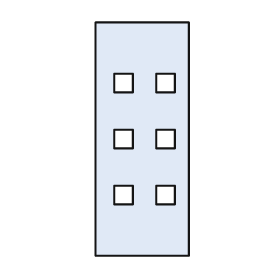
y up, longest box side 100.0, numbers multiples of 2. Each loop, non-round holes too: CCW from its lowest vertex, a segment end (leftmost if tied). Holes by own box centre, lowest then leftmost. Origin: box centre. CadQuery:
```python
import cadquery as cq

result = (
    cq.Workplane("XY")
    .moveTo(-20.0, -50.0)
    .lineTo(20.0, -50.0)
    .lineTo(20.0, 50.0)
    .lineTo(-20.0, 50.0)
    .close()
    .moveTo(-12.0, -28.0)
    .lineTo(-4.0, -28.0)
    .lineTo(-4.0, -20.0)
    .lineTo(-12.0, -20.0)
    .close()
    .moveTo(6.0, -28.0)
    .lineTo(14.0, -28.0)
    .lineTo(14.0, -20.0)
    .lineTo(6.0, -20.0)
    .close()
    .moveTo(-12.0, -4.0)
    .lineTo(-4.0, -4.0)
    .lineTo(-4.0, 4.0)
    .lineTo(-12.0, 4.0)
    .close()
    .moveTo(6.0, -4.0)
    .lineTo(14.0, -4.0)
    .lineTo(14.0, 4.0)
    .lineTo(6.0, 4.0)
    .close()
    .moveTo(-12.0, 20.0)
    .lineTo(-4.0, 20.0)
    .lineTo(-4.0, 28.0)
    .lineTo(-12.0, 28.0)
    .close()
    .moveTo(6.0, 20.0)
    .lineTo(14.0, 20.0)
    .lineTo(14.0, 28.0)
    .lineTo(6.0, 28.0)
    .close()
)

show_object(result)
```